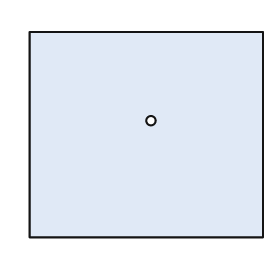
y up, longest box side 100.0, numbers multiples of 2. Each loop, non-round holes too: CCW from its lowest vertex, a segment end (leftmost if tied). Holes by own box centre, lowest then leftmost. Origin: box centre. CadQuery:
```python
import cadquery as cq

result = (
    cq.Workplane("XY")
    .moveTo(-50.0, -44.0)
    .lineTo(50.0, -44.0)
    .lineTo(50.0, 44.0)
    .lineTo(-50.0, 44.0)
    .close()
    .moveTo(2.0, 6.0)
    .circle(2.0)
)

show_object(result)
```